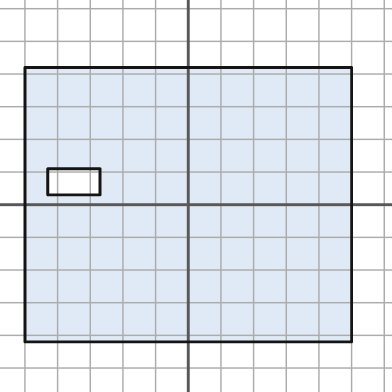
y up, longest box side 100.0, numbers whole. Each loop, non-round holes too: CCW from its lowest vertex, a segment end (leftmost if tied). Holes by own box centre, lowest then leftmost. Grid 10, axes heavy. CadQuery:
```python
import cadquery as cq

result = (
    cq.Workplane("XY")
    .moveTo(-50.0, -42.0)
    .lineTo(50.0, -42.0)
    .lineTo(50.0, 42.0)
    .lineTo(-50.0, 42.0)
    .close()
    .moveTo(-43.0, 3.0)
    .lineTo(-27.0, 3.0)
    .lineTo(-27.0, 11.0)
    .lineTo(-43.0, 11.0)
    .close()
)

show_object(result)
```